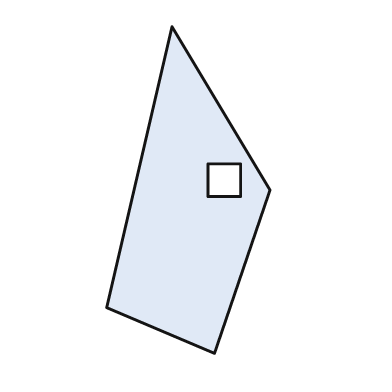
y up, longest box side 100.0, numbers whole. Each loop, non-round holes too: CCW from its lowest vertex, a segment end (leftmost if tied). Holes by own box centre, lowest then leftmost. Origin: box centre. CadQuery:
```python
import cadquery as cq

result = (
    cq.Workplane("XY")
    .moveTo(8.0, -50.0)
    .lineTo(25.0, 0.0)
    .lineTo(-5.0, 50.0)
    .lineTo(-25.0, -36.0)
    .close()
    .moveTo(6.0, -2.0)
    .lineTo(16.0, -2.0)
    .lineTo(16.0, 8.0)
    .lineTo(6.0, 8.0)
    .close()
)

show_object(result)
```